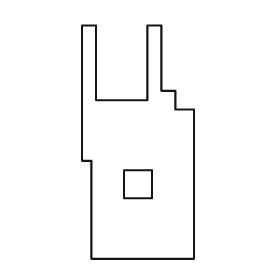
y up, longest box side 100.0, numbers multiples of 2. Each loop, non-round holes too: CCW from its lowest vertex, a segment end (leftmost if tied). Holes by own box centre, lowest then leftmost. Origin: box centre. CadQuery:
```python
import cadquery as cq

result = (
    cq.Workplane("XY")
    .moveTo(-20.0, -50.0)
    .lineTo(24.0, -50.0)
    .lineTo(24.0, 14.0)
    .lineTo(16.0, 14.0)
    .lineTo(16.0, 22.0)
    .lineTo(10.0, 22.0)
    .lineTo(10.0, 50.0)
    .lineTo(4.0, 50.0)
    .lineTo(4.0, 18.0)
    .lineTo(-18.0, 18.0)
    .lineTo(-18.0, 50.0)
    .lineTo(-24.0, 50.0)
    .lineTo(-24.0, -8.0)
    .lineTo(-20.0, -8.0)
    .close()
    .moveTo(-6.0, -24.0)
    .lineTo(6.0, -24.0)
    .lineTo(6.0, -12.0)
    .lineTo(-6.0, -12.0)
    .close()
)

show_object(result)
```